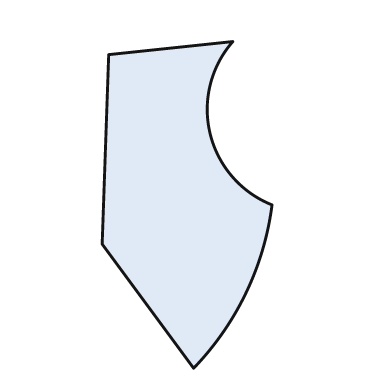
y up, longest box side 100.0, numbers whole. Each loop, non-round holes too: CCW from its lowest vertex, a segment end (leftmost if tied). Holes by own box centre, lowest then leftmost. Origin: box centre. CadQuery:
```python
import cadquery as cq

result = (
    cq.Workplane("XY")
    .moveTo(2.0, -50.0)
    .threePointArc((18.0, -27.0), (26.0, 0.0))
    .threePointArc((7.0, 22.0), (14.0, 50.0))
    .lineTo(-24.0, 46.0)
    .lineTo(-26.0, -12.0)
    .close()
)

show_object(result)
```